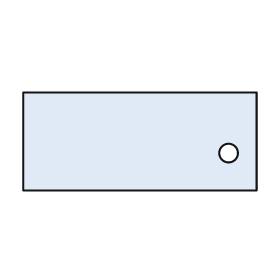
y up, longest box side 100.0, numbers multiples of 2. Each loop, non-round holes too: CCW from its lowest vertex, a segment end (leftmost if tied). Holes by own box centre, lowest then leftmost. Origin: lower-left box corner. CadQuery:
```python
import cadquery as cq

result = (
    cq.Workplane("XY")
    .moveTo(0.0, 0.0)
    .lineTo(100.0, 0.0)
    .lineTo(100.0, 42.0)
    .lineTo(0.0, 42.0)
    .close()
    .moveTo(88.0, 16.0)
    .circle(4.0)
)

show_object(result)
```